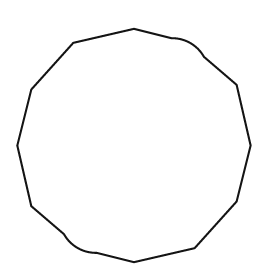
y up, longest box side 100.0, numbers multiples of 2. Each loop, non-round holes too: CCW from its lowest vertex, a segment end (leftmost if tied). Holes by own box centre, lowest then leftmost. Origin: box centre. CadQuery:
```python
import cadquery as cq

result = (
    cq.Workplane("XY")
    .moveTo(0.0, -50.0)
    .lineTo(26.0, -44.0)
    .lineTo(44.0, -24.0)
    .lineTo(50.0, 0.0)
    .lineTo(44.0, 26.0)
    .lineTo(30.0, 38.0)
    .threePointArc((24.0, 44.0), (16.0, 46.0))
    .lineTo(0.0, 50.0)
    .lineTo(-26.0, 44.0)
    .lineTo(-44.0, 24.0)
    .lineTo(-50.0, 0.0)
    .lineTo(-44.0, -26.0)
    .lineTo(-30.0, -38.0)
    .threePointArc((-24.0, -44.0), (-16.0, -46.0))
    .close()
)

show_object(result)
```